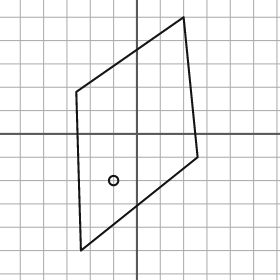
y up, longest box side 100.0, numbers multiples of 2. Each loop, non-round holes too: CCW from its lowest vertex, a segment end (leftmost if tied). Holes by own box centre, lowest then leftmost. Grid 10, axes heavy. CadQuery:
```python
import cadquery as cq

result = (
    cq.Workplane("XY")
    .moveTo(-24.0, -50.0)
    .lineTo(26.0, -10.0)
    .lineTo(20.0, 50.0)
    .lineTo(-26.0, 18.0)
    .close()
    .moveTo(-10.0, -20.0)
    .circle(2.0)
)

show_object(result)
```